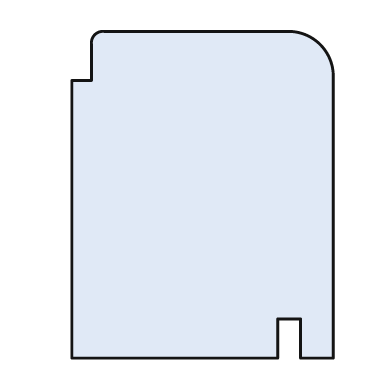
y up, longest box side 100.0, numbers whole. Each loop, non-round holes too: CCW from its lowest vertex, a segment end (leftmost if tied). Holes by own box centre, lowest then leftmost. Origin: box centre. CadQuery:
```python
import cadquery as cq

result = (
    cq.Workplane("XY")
    .moveTo(-40.0, -50.0)
    .lineTo(23.0, -50.0)
    .lineTo(23.0, -38.0)
    .lineTo(30.0, -38.0)
    .lineTo(30.0, -50.0)
    .lineTo(40.0, -50.0)
    .lineTo(40.0, 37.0)
    .threePointArc((36.0, 46.0), (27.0, 50.0))
    .lineTo(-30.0, 50.0)
    .threePointArc((-33.0, 49.0), (-34.0, 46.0))
    .lineTo(-34.0, 35.0)
    .lineTo(-40.0, 35.0)
    .close()
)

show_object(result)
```